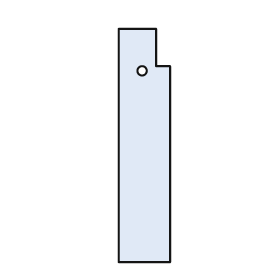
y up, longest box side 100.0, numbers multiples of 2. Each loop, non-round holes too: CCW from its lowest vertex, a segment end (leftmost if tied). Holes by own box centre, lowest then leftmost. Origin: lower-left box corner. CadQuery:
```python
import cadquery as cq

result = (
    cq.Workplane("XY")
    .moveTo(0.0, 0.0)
    .lineTo(22.0, 0.0)
    .lineTo(22.0, 84.0)
    .lineTo(16.0, 84.0)
    .lineTo(16.0, 100.0)
    .lineTo(0.0, 100.0)
    .close()
    .moveTo(10.0, 82.0)
    .circle(2.0)
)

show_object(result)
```